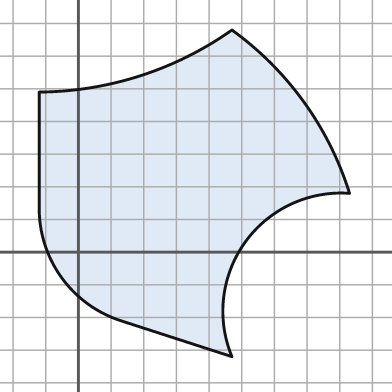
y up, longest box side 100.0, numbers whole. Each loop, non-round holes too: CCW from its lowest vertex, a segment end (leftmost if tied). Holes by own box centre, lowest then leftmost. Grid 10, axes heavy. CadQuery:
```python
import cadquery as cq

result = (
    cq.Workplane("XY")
    .moveTo(47.0, -32.0)
    .threePointArc((51.0, 3.0), (83.0, 18.0))
    .threePointArc((69.0, 46.0), (47.0, 68.0))
    .threePointArc((19.0, 54.0), (-12.0, 49.0))
    .lineTo(-12.0, 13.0)
    .threePointArc((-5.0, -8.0), (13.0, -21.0))
    .close()
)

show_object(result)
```